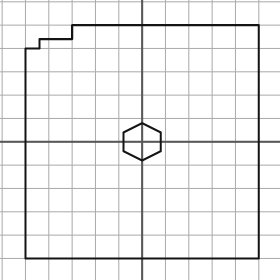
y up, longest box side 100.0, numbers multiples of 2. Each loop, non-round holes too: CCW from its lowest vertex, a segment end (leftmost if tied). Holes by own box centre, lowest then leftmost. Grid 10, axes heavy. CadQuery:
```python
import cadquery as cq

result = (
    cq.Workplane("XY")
    .moveTo(-50.0, -50.0)
    .lineTo(50.0, -50.0)
    .lineTo(50.0, 50.0)
    .lineTo(-30.0, 50.0)
    .lineTo(-30.0, 44.0)
    .lineTo(-44.0, 44.0)
    .lineTo(-44.0, 40.0)
    .lineTo(-50.0, 40.0)
    .close()
    .moveTo(0.0, -8.0)
    .lineTo(8.0, -4.0)
    .lineTo(8.0, 4.0)
    .lineTo(0.0, 8.0)
    .lineTo(-8.0, 4.0)
    .lineTo(-8.0, -4.0)
    .close()
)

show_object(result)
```